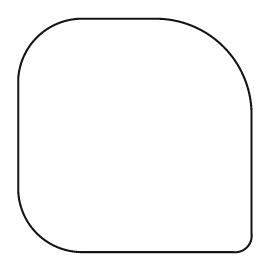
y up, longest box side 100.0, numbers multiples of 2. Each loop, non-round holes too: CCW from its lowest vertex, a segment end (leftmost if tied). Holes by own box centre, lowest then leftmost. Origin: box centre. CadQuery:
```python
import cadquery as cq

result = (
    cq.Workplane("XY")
    .moveTo(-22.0, -50.0)
    .lineTo(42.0, -50.0)
    .threePointArc((48.0, -48.0), (50.0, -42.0))
    .lineTo(50.0, 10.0)
    .threePointArc((38.0, 38.0), (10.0, 50.0))
    .lineTo(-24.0, 50.0)
    .threePointArc((-42.0, 42.0), (-50.0, 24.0))
    .lineTo(-50.0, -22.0)
    .threePointArc((-42.0, -42.0), (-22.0, -50.0))
    .close()
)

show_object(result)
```